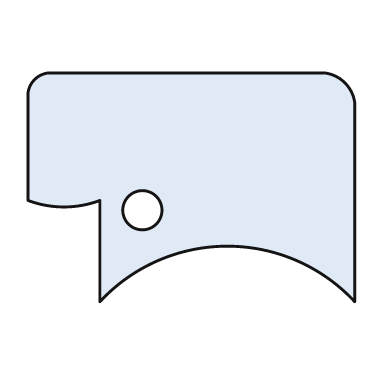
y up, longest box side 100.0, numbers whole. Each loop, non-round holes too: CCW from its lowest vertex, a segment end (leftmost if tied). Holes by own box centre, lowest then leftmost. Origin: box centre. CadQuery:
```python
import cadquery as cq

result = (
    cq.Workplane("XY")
    .moveTo(-28.0, -35.0)
    .threePointArc((11.0, -18.0), (50.0, -35.0))
    .lineTo(50.0, 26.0)
    .threePointArc((47.0, 32.0), (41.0, 35.0))
    .lineTo(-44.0, 35.0)
    .threePointArc((-48.0, 33.0), (-50.0, 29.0))
    .lineTo(-50.0, -4.0)
    .threePointArc((-39.0, -6.0), (-28.0, -4.0))
    .close()
    .moveTo(-15.0, -7.0)
    .circle(6.0)
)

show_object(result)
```